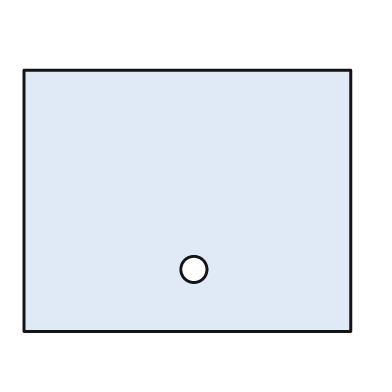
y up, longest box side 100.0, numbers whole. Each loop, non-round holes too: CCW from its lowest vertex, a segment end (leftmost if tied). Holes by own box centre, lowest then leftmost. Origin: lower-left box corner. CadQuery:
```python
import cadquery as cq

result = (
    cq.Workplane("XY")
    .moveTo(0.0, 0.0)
    .lineTo(100.0, 0.0)
    .lineTo(100.0, 80.0)
    .lineTo(0.0, 80.0)
    .close()
    .moveTo(52.0, 19.0)
    .circle(4.0)
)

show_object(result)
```